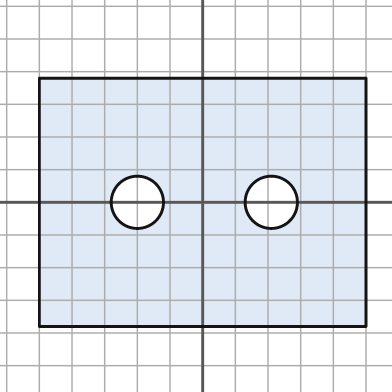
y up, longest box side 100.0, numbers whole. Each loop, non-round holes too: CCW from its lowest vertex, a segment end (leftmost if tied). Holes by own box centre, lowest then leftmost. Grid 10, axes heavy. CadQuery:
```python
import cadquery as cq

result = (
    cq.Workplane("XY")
    .moveTo(-50.0, -38.0)
    .lineTo(50.0, -38.0)
    .lineTo(50.0, 38.0)
    .lineTo(-50.0, 38.0)
    .close()
    .moveTo(-20.0, 0.0)
    .circle(8.0)
    .moveTo(21.0, 0.0)
    .circle(8.0)
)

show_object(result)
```